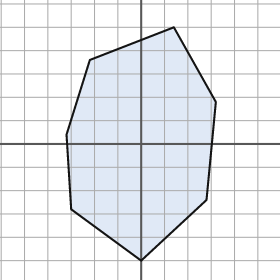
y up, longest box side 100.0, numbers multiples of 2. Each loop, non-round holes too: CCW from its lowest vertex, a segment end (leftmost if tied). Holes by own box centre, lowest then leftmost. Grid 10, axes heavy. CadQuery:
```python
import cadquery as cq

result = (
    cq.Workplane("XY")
    .moveTo(0.0, -50.0)
    .lineTo(28.0, -24.0)
    .lineTo(32.0, 18.0)
    .lineTo(14.0, 50.0)
    .lineTo(-22.0, 36.0)
    .lineTo(-32.0, 4.0)
    .lineTo(-30.0, -28.0)
    .close()
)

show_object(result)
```